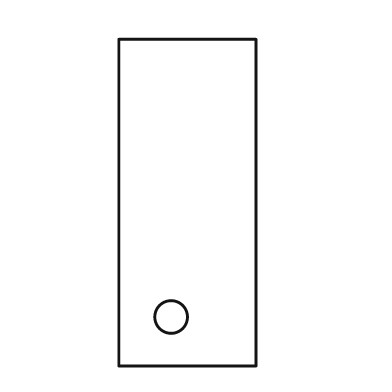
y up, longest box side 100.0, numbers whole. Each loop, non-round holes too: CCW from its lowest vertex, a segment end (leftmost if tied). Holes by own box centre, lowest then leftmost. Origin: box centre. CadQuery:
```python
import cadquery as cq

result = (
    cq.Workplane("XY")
    .moveTo(-21.0, -50.0)
    .lineTo(21.0, -50.0)
    .lineTo(21.0, 50.0)
    .lineTo(-21.0, 50.0)
    .close()
    .moveTo(-5.0, -35.0)
    .circle(5.0)
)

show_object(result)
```